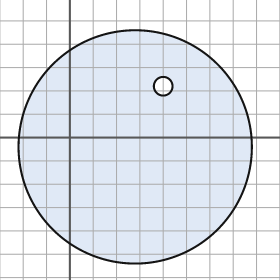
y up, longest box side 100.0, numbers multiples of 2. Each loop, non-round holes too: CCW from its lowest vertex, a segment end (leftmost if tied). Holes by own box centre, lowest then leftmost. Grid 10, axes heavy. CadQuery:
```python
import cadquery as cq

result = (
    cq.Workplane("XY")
    .moveTo(28.0, -4.0)
    .circle(50.0)
    .moveTo(40.0, 22.0)
    .circle(4.0)
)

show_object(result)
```